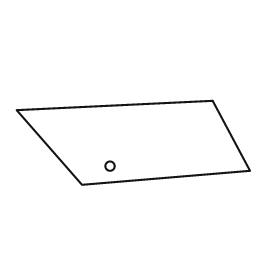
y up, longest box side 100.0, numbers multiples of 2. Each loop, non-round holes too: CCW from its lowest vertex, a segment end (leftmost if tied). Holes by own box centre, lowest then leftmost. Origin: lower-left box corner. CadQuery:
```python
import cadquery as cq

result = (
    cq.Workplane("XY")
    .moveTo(28.0, 0.0)
    .lineTo(100.0, 6.0)
    .lineTo(84.0, 36.0)
    .lineTo(0.0, 32.0)
    .close()
    .moveTo(40.0, 8.0)
    .circle(2.0)
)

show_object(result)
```